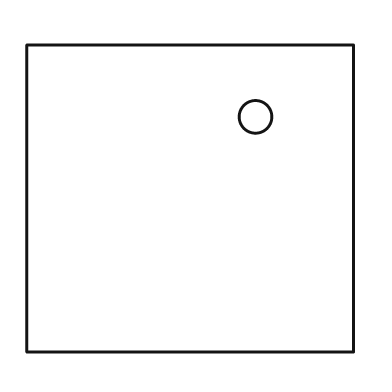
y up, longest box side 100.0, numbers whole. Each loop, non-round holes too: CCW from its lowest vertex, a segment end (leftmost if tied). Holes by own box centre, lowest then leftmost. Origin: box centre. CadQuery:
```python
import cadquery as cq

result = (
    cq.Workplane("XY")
    .moveTo(-50.0, -47.0)
    .lineTo(50.0, -47.0)
    .lineTo(50.0, 47.0)
    .lineTo(-50.0, 47.0)
    .close()
    .moveTo(20.0, 25.0)
    .circle(5.0)
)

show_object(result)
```